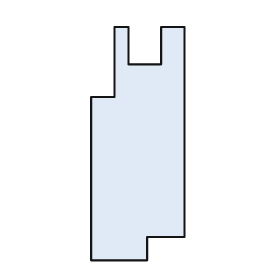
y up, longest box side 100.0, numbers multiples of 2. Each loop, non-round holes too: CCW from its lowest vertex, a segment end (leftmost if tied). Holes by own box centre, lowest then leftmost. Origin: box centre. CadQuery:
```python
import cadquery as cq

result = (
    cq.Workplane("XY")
    .moveTo(-20.0, -50.0)
    .lineTo(4.0, -50.0)
    .lineTo(4.0, -40.0)
    .lineTo(20.0, -40.0)
    .lineTo(20.0, 50.0)
    .lineTo(10.0, 50.0)
    .lineTo(10.0, 34.0)
    .lineTo(-4.0, 34.0)
    .lineTo(-4.0, 50.0)
    .lineTo(-10.0, 50.0)
    .lineTo(-10.0, 20.0)
    .lineTo(-20.0, 20.0)
    .close()
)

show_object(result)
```